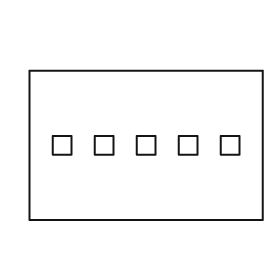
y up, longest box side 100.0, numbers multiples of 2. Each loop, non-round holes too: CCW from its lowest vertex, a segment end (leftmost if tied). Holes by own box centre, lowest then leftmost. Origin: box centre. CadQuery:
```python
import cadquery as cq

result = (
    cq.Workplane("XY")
    .moveTo(-50.0, -32.0)
    .lineTo(50.0, -32.0)
    .lineTo(50.0, 32.0)
    .lineTo(-50.0, 32.0)
    .close()
    .moveTo(-40.0, -4.0)
    .lineTo(-32.0, -4.0)
    .lineTo(-32.0, 4.0)
    .lineTo(-40.0, 4.0)
    .close()
    .moveTo(-22.0, -4.0)
    .lineTo(-14.0, -4.0)
    .lineTo(-14.0, 4.0)
    .lineTo(-22.0, 4.0)
    .close()
    .moveTo(-4.0, -4.0)
    .lineTo(4.0, -4.0)
    .lineTo(4.0, 4.0)
    .lineTo(-4.0, 4.0)
    .close()
    .moveTo(14.0, -4.0)
    .lineTo(22.0, -4.0)
    .lineTo(22.0, 4.0)
    .lineTo(14.0, 4.0)
    .close()
    .moveTo(32.0, -4.0)
    .lineTo(40.0, -4.0)
    .lineTo(40.0, 4.0)
    .lineTo(32.0, 4.0)
    .close()
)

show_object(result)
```